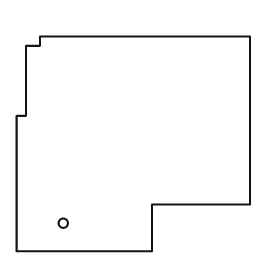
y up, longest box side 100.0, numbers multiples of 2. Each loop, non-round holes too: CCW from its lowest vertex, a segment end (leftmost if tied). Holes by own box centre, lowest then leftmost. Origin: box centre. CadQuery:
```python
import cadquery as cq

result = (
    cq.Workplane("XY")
    .moveTo(-50.0, -46.0)
    .lineTo(8.0, -46.0)
    .lineTo(8.0, -26.0)
    .lineTo(50.0, -26.0)
    .lineTo(50.0, 46.0)
    .lineTo(-40.0, 46.0)
    .lineTo(-40.0, 42.0)
    .lineTo(-46.0, 42.0)
    .lineTo(-46.0, 12.0)
    .lineTo(-50.0, 12.0)
    .close()
    .moveTo(-30.0, -34.0)
    .circle(2.0)
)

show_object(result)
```